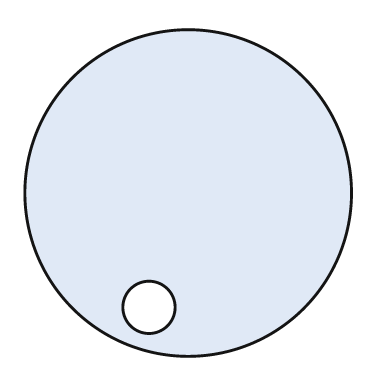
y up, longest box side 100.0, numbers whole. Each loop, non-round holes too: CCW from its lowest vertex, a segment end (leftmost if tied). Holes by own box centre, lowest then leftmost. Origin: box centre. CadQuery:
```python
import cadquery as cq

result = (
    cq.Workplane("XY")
    .moveTo(0.0, 0.0)
    .circle(50.0)
    .moveTo(-12.0, -35.0)
    .circle(8.0)
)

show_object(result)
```